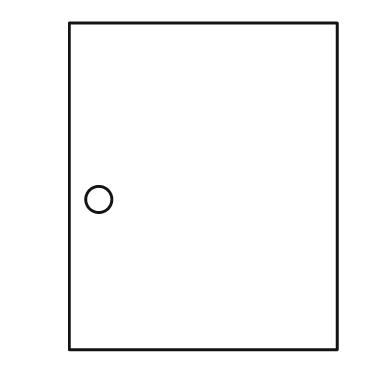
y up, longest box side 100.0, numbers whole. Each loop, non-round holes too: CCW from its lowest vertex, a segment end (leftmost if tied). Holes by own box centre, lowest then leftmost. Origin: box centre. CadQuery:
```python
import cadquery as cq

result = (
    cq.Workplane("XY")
    .moveTo(-41.0, -50.0)
    .lineTo(41.0, -50.0)
    .lineTo(41.0, 50.0)
    .lineTo(-41.0, 50.0)
    .close()
    .moveTo(-32.0, -4.0)
    .circle(4.0)
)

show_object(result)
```